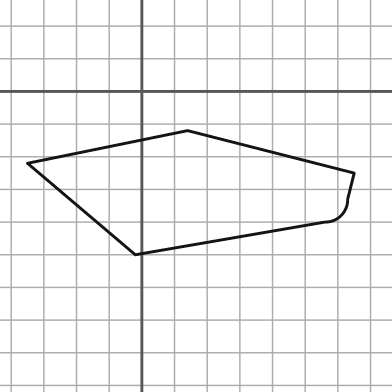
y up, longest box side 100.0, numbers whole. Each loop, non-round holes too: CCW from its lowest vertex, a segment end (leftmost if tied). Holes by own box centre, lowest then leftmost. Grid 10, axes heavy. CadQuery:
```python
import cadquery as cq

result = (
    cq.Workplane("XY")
    .moveTo(-2.0, -50.0)
    .lineTo(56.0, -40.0)
    .threePointArc((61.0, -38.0), (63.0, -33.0))
    .lineTo(65.0, -25.0)
    .lineTo(14.0, -12.0)
    .lineTo(-35.0, -22.0)
    .close()
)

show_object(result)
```